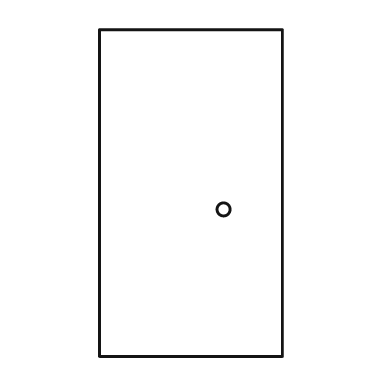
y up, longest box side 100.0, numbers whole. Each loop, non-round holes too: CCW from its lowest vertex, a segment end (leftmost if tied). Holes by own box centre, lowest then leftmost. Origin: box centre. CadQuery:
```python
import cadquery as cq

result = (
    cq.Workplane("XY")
    .moveTo(-28.0, -50.0)
    .lineTo(28.0, -50.0)
    .lineTo(28.0, 50.0)
    .lineTo(-28.0, 50.0)
    .close()
    .moveTo(10.0, -5.0)
    .circle(2.0)
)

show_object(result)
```